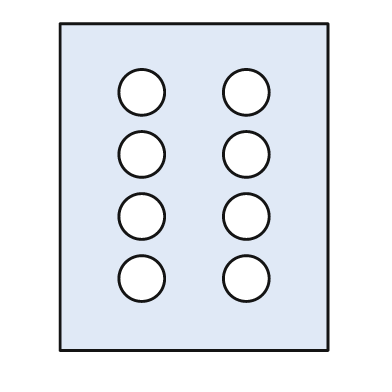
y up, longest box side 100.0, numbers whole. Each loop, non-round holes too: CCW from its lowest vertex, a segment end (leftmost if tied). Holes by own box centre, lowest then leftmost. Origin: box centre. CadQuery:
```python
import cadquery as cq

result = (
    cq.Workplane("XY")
    .moveTo(-41.0, -50.0)
    .lineTo(41.0, -50.0)
    .lineTo(41.0, 50.0)
    .lineTo(-41.0, 50.0)
    .close()
    .moveTo(-16.0, -28.0)
    .circle(7.0)
    .moveTo(16.0, -28.0)
    .circle(7.0)
    .moveTo(-16.0, -9.0)
    .circle(7.0)
    .moveTo(16.0, -9.0)
    .circle(7.0)
    .moveTo(-16.0, 10.0)
    .circle(7.0)
    .moveTo(16.0, 10.0)
    .circle(7.0)
    .moveTo(-16.0, 29.0)
    .circle(7.0)
    .moveTo(16.0, 29.0)
    .circle(7.0)
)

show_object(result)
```